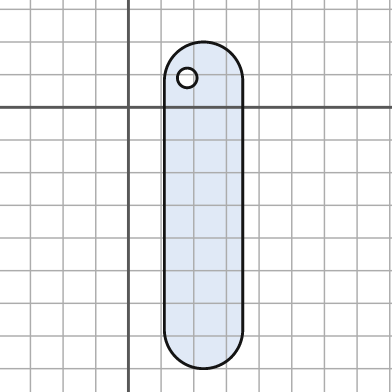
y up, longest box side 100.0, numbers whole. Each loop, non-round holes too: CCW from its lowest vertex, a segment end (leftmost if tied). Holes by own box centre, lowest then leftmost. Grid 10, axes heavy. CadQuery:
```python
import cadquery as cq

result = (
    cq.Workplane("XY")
    .moveTo(11.0, -68.0)
    .threePointArc((23.0, -80.0), (35.0, -68.0))
    .lineTo(35.0, 8.0)
    .threePointArc((23.0, 20.0), (11.0, 8.0))
    .close()
    .moveTo(18.0, 9.0)
    .circle(3.0)
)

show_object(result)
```